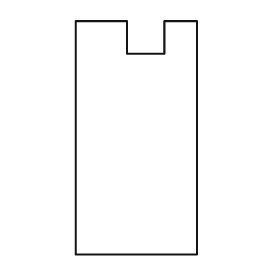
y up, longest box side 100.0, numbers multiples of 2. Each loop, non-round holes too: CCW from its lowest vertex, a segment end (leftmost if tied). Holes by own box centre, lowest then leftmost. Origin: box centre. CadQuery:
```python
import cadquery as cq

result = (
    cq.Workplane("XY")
    .moveTo(-26.0, -50.0)
    .lineTo(26.0, -50.0)
    .lineTo(26.0, 50.0)
    .lineTo(12.0, 50.0)
    .lineTo(12.0, 36.0)
    .lineTo(-4.0, 36.0)
    .lineTo(-4.0, 50.0)
    .lineTo(-26.0, 50.0)
    .close()
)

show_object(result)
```